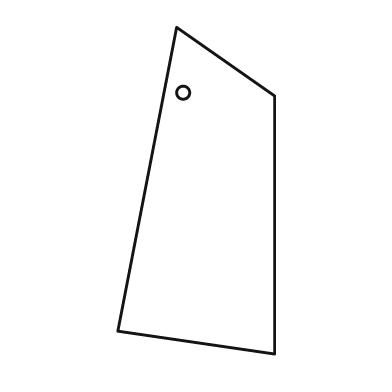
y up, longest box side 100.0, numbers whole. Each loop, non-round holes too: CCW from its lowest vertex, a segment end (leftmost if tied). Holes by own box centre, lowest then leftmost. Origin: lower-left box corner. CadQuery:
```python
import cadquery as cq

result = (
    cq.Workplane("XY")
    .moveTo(48.0, 0.0)
    .lineTo(48.0, 79.0)
    .lineTo(18.0, 100.0)
    .lineTo(0.0, 7.0)
    .close()
    .moveTo(20.0, 80.0)
    .circle(2.0)
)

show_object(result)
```